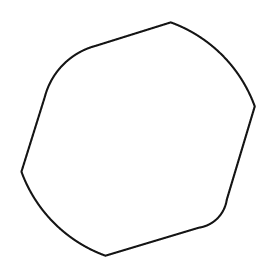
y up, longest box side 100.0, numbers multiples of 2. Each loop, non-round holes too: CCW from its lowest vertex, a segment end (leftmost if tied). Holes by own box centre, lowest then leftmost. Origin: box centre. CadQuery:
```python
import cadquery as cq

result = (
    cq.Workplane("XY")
    .moveTo(-14.0, -50.0)
    .lineTo(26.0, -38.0)
    .threePointArc((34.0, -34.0), (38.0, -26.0))
    .lineTo(50.0, 14.0)
    .threePointArc((36.0, 36.0), (14.0, 50.0))
    .lineTo(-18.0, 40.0)
    .threePointArc((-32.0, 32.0), (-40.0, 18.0))
    .lineTo(-50.0, -14.0)
    .threePointArc((-36.0, -36.0), (-14.0, -50.0))
    .close()
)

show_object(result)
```